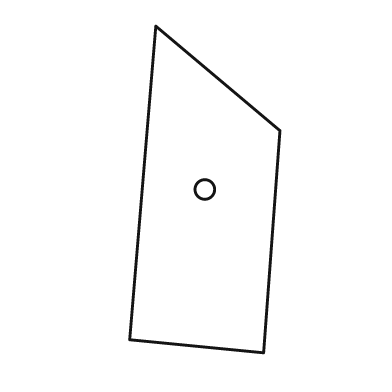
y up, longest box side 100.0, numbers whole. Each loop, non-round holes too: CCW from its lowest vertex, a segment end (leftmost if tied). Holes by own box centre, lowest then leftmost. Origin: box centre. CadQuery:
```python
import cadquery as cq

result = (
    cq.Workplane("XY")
    .moveTo(18.0, -50.0)
    .lineTo(23.0, 18.0)
    .lineTo(-15.0, 50.0)
    .lineTo(-23.0, -46.0)
    .close()
    .moveTo(0.0, 0.0)
    .circle(3.0)
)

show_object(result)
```